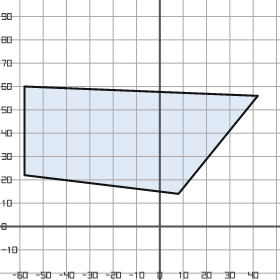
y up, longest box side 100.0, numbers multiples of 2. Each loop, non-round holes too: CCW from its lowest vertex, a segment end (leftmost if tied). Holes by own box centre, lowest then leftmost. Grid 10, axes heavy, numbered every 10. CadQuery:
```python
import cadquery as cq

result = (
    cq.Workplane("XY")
    .moveTo(8.0, 14.0)
    .lineTo(42.0, 56.0)
    .lineTo(-58.0, 60.0)
    .lineTo(-58.0, 22.0)
    .close()
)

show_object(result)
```